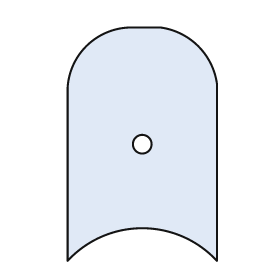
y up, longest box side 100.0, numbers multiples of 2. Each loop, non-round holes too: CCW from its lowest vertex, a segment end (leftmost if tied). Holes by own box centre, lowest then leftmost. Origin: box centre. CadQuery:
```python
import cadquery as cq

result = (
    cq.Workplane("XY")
    .moveTo(-32.0, -50.0)
    .threePointArc((0.0, -36.0), (32.0, -50.0))
    .lineTo(32.0, 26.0)
    .threePointArc((24.0, 42.0), (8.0, 50.0))
    .lineTo(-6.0, 50.0)
    .threePointArc((-24.0, 42.0), (-32.0, 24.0))
    .close()
    .moveTo(0.0, 0.0)
    .circle(4.0)
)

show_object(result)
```